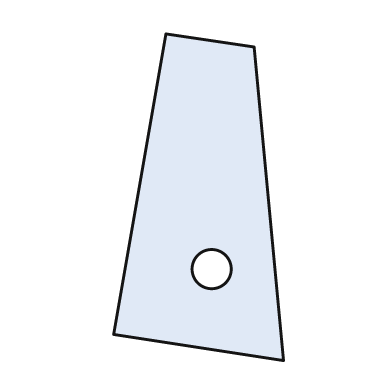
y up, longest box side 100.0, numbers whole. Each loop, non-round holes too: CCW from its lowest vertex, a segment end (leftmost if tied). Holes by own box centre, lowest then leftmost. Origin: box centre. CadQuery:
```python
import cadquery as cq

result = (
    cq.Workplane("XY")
    .moveTo(26.0, -50.0)
    .lineTo(17.0, 46.0)
    .lineTo(-10.0, 50.0)
    .lineTo(-26.0, -42.0)
    .close()
    .moveTo(4.0, -22.0)
    .circle(6.0)
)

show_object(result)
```